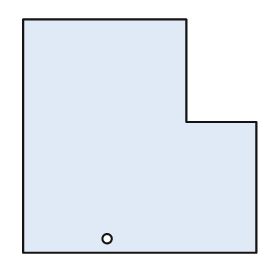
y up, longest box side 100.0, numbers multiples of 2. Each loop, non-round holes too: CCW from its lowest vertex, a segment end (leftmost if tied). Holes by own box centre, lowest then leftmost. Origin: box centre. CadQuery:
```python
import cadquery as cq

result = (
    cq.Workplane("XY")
    .moveTo(-50.0, -50.0)
    .lineTo(50.0, -50.0)
    .lineTo(50.0, 6.0)
    .lineTo(20.0, 6.0)
    .lineTo(20.0, 50.0)
    .lineTo(-50.0, 50.0)
    .close()
    .moveTo(-14.0, -44.0)
    .circle(2.0)
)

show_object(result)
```